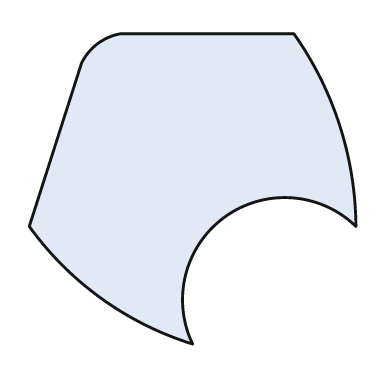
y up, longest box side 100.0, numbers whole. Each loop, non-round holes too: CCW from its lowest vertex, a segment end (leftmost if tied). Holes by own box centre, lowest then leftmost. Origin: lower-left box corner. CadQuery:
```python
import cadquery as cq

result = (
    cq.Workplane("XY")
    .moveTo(50.0, 0.0)
    .threePointArc((60.0, 39.0), (100.0, 36.0))
    .threePointArc((95.0, 67.0), (81.0, 95.0))
    .lineTo(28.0, 95.0)
    .threePointArc((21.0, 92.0), (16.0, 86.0))
    .lineTo(0.0, 36.0)
    .threePointArc((22.0, 14.0), (50.0, 0.0))
    .close()
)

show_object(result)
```